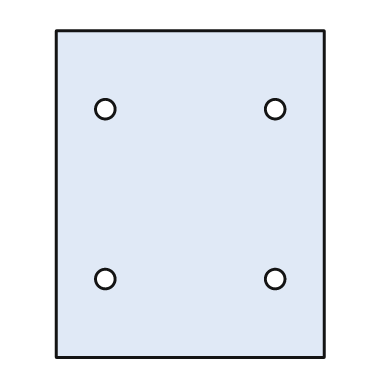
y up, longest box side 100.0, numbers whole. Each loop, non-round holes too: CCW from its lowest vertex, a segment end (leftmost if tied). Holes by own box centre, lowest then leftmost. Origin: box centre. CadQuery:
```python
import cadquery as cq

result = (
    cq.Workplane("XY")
    .moveTo(-41.0, -50.0)
    .lineTo(41.0, -50.0)
    .lineTo(41.0, 50.0)
    .lineTo(-41.0, 50.0)
    .close()
    .moveTo(-26.0, -26.0)
    .circle(3.0)
    .moveTo(26.0, -26.0)
    .circle(3.0)
    .moveTo(-26.0, 26.0)
    .circle(3.0)
    .moveTo(26.0, 26.0)
    .circle(3.0)
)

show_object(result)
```